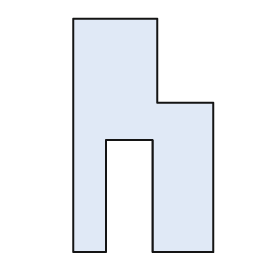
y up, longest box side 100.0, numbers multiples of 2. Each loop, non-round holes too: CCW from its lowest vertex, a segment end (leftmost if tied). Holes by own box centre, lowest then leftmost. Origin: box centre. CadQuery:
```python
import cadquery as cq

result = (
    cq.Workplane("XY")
    .moveTo(-30.0, -50.0)
    .lineTo(-16.0, -50.0)
    .lineTo(-16.0, -2.0)
    .lineTo(4.0, -2.0)
    .lineTo(4.0, -50.0)
    .lineTo(30.0, -50.0)
    .lineTo(30.0, 14.0)
    .lineTo(6.0, 14.0)
    .lineTo(6.0, 50.0)
    .lineTo(-30.0, 50.0)
    .close()
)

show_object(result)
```